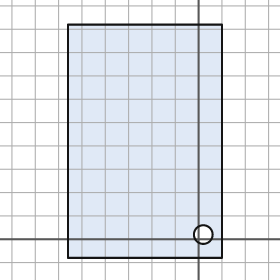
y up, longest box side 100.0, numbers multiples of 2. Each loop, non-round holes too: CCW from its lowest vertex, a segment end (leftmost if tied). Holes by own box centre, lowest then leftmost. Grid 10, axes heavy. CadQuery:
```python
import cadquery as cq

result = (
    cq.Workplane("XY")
    .moveTo(-56.0, -8.0)
    .lineTo(10.0, -8.0)
    .lineTo(10.0, 92.0)
    .lineTo(-56.0, 92.0)
    .close()
    .moveTo(2.0, 2.0)
    .circle(4.0)
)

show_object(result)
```